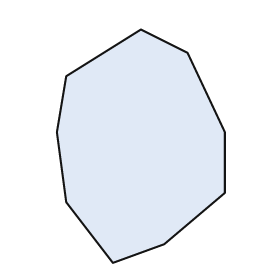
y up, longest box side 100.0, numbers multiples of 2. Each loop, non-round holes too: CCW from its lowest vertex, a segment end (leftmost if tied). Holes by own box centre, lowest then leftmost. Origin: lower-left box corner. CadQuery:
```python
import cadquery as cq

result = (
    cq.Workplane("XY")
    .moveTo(24.0, 0.0)
    .lineTo(46.0, 8.0)
    .lineTo(72.0, 30.0)
    .lineTo(72.0, 56.0)
    .lineTo(56.0, 90.0)
    .lineTo(36.0, 100.0)
    .lineTo(4.0, 80.0)
    .lineTo(0.0, 56.0)
    .lineTo(4.0, 26.0)
    .close()
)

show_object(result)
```